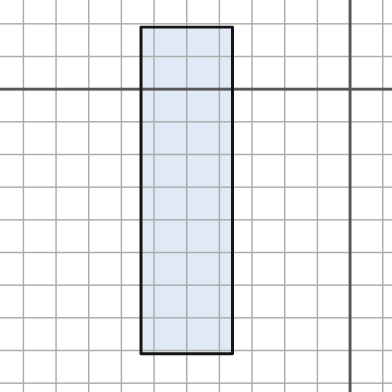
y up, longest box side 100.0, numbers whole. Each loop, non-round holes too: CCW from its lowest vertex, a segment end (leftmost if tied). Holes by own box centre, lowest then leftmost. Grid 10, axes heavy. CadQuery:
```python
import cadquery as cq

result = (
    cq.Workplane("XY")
    .moveTo(-64.0, -81.0)
    .lineTo(-36.0, -81.0)
    .lineTo(-36.0, 19.0)
    .lineTo(-64.0, 19.0)
    .close()
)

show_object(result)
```